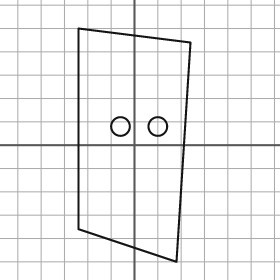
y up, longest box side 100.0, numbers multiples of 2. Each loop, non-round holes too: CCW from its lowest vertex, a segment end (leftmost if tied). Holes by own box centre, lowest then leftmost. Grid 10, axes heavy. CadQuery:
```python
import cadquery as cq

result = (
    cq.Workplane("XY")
    .moveTo(18.0, -50.0)
    .lineTo(24.0, 44.0)
    .lineTo(-24.0, 50.0)
    .lineTo(-24.0, -36.0)
    .close()
    .moveTo(-6.0, 8.0)
    .circle(4.0)
    .moveTo(10.0, 8.0)
    .circle(4.0)
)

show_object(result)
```